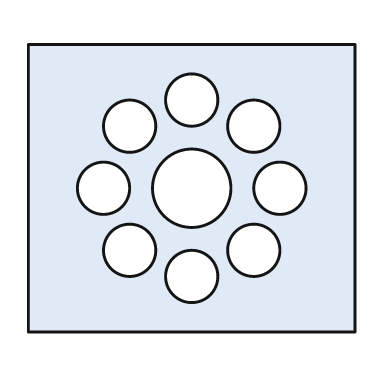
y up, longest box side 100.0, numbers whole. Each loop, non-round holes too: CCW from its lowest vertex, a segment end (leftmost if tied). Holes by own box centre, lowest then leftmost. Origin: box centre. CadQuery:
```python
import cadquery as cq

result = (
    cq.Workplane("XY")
    .moveTo(-50.0, -44.0)
    .lineTo(50.0, -44.0)
    .lineTo(50.0, 44.0)
    .lineTo(-50.0, 44.0)
    .close()
    .moveTo(0.0, -27.0)
    .circle(8.0)
    .moveTo(-19.0, -19.0)
    .circle(8.0)
    .moveTo(19.0, -19.0)
    .circle(8.0)
    .moveTo(-27.0, 0.0)
    .circle(8.0)
    .moveTo(0.0, 0.0)
    .circle(12.0)
    .moveTo(27.0, 0.0)
    .circle(8.0)
    .moveTo(-19.0, 19.0)
    .circle(8.0)
    .moveTo(19.0, 19.0)
    .circle(8.0)
    .moveTo(0.0, 27.0)
    .circle(8.0)
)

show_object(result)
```